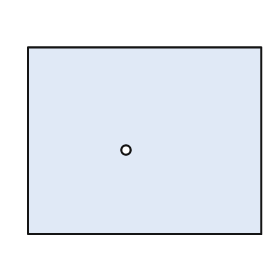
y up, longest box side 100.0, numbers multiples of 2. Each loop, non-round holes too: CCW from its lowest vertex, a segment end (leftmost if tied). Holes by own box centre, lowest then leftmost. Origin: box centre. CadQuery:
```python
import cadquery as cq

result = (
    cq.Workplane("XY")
    .moveTo(-50.0, -40.0)
    .lineTo(50.0, -40.0)
    .lineTo(50.0, 40.0)
    .lineTo(-50.0, 40.0)
    .close()
    .moveTo(-8.0, -4.0)
    .circle(2.0)
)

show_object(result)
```